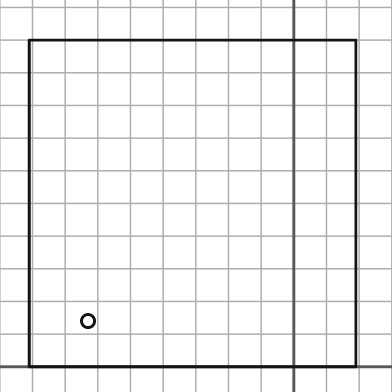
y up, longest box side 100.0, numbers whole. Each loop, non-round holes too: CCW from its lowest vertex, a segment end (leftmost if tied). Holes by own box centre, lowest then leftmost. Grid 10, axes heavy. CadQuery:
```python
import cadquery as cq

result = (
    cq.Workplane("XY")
    .moveTo(-81.0, 0.0)
    .lineTo(19.0, 0.0)
    .lineTo(19.0, 100.0)
    .lineTo(-81.0, 100.0)
    .close()
    .moveTo(-63.0, 14.0)
    .circle(2.0)
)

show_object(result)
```